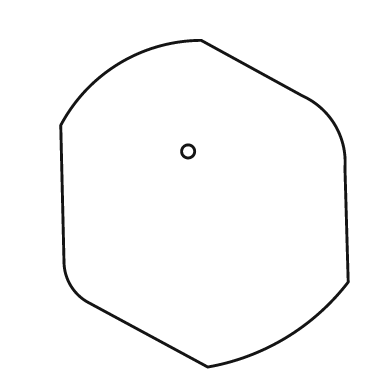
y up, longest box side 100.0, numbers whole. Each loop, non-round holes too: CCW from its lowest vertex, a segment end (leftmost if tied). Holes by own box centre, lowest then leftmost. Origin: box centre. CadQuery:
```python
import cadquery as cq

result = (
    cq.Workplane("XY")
    .moveTo(1.0, -50.0)
    .threePointArc((25.0, -41.0), (44.0, -24.0))
    .lineTo(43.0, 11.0)
    .threePointArc((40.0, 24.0), (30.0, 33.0))
    .lineTo(-1.0, 50.0)
    .threePointArc((-26.0, 43.0), (-44.0, 24.0))
    .lineTo(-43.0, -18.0)
    .threePointArc((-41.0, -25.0), (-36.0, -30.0))
    .close()
    .moveTo(-5.0, 16.0)
    .circle(2.0)
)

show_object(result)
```